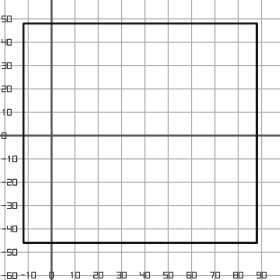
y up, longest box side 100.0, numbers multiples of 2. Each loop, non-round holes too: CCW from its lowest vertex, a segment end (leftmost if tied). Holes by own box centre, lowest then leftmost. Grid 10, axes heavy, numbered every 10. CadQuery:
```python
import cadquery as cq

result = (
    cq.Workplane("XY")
    .moveTo(-12.0, -46.0)
    .lineTo(88.0, -46.0)
    .lineTo(88.0, 48.0)
    .lineTo(-12.0, 48.0)
    .close()
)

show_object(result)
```